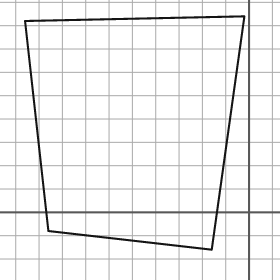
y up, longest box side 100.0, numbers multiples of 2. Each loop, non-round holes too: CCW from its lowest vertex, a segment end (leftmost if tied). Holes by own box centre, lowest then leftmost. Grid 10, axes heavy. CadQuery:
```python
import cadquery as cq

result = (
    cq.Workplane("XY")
    .moveTo(-16.0, -16.0)
    .lineTo(-2.0, 84.0)
    .lineTo(-96.0, 82.0)
    .lineTo(-86.0, -8.0)
    .close()
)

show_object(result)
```